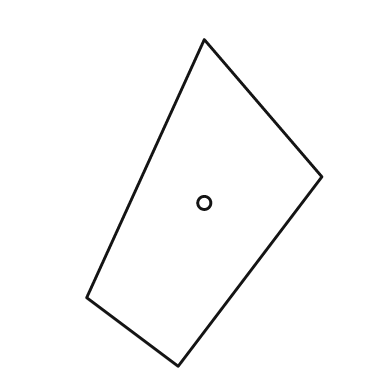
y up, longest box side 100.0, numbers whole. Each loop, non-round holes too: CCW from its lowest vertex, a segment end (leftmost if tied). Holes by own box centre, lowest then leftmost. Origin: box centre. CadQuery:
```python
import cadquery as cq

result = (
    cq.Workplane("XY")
    .moveTo(-8.0, -50.0)
    .lineTo(36.0, 8.0)
    .lineTo(0.0, 50.0)
    .lineTo(-36.0, -29.0)
    .close()
    .moveTo(0.0, 0.0)
    .circle(2.0)
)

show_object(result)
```